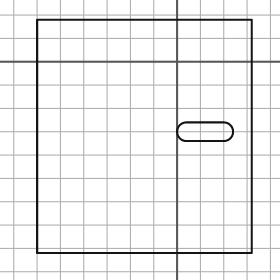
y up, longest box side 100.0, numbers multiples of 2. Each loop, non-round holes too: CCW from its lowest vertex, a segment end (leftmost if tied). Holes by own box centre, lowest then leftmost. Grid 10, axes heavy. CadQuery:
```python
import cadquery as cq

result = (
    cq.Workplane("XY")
    .moveTo(-60.0, -82.0)
    .lineTo(32.0, -82.0)
    .lineTo(32.0, 18.0)
    .lineTo(-60.0, 18.0)
    .close()
    .moveTo(4.0, -34.0)
    .lineTo(20.0, -34.0)
    .threePointArc((24.0, -30.0), (20.0, -26.0))
    .lineTo(4.0, -26.0)
    .threePointArc((0.0, -30.0), (4.0, -34.0))
    .close()
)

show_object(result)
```